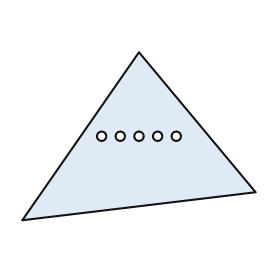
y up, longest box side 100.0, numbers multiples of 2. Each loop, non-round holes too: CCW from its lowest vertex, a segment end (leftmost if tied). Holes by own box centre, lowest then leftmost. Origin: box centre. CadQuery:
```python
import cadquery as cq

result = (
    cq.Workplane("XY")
    .moveTo(-50.0, -36.0)
    .lineTo(50.0, -24.0)
    .lineTo(0.0, 36.0)
    .close()
    .moveTo(-16.0, 0.0)
    .circle(2.0)
    .moveTo(-8.0, 0.0)
    .circle(2.0)
    .moveTo(0.0, 0.0)
    .circle(2.0)
    .moveTo(8.0, 0.0)
    .circle(2.0)
    .moveTo(16.0, 0.0)
    .circle(2.0)
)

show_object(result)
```